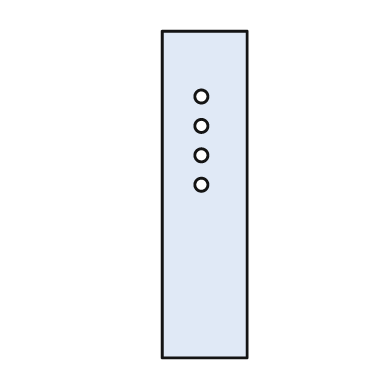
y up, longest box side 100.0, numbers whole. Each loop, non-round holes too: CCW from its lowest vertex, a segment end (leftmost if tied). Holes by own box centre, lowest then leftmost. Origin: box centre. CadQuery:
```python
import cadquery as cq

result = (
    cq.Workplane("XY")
    .moveTo(-13.0, -50.0)
    .lineTo(13.0, -50.0)
    .lineTo(13.0, 50.0)
    .lineTo(-13.0, 50.0)
    .close()
    .moveTo(-1.0, 3.0)
    .circle(2.0)
    .moveTo(-1.0, 12.0)
    .circle(2.0)
    .moveTo(-1.0, 21.0)
    .circle(2.0)
    .moveTo(-1.0, 30.0)
    .circle(2.0)
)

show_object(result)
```